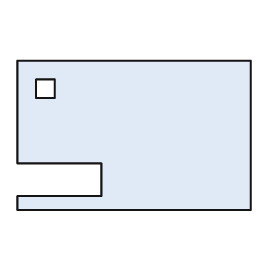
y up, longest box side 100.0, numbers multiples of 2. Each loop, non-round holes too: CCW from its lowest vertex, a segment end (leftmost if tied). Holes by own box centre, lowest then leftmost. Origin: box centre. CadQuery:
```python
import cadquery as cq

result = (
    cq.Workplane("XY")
    .moveTo(-50.0, -32.0)
    .lineTo(50.0, -32.0)
    .lineTo(50.0, 32.0)
    .lineTo(-50.0, 32.0)
    .lineTo(-50.0, -12.0)
    .lineTo(-14.0, -12.0)
    .lineTo(-14.0, -26.0)
    .lineTo(-50.0, -26.0)
    .close()
    .moveTo(-42.0, 16.0)
    .lineTo(-34.0, 16.0)
    .lineTo(-34.0, 24.0)
    .lineTo(-42.0, 24.0)
    .close()
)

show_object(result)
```